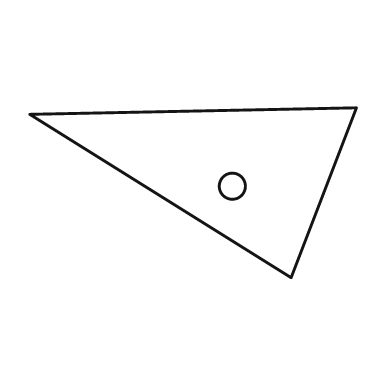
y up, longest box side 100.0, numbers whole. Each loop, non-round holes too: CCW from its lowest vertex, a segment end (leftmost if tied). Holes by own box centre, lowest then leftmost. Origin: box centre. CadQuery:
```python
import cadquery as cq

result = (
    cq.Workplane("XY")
    .moveTo(30.0, -26.0)
    .lineTo(50.0, 26.0)
    .lineTo(-50.0, 24.0)
    .close()
    .moveTo(12.0, 2.0)
    .circle(4.0)
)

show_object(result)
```